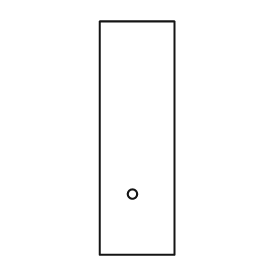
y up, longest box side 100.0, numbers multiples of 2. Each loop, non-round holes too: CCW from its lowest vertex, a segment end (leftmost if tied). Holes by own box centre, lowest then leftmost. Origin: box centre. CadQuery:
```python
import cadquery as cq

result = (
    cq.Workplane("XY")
    .moveTo(-16.0, -50.0)
    .lineTo(16.0, -50.0)
    .lineTo(16.0, 50.0)
    .lineTo(-16.0, 50.0)
    .close()
    .moveTo(-2.0, -24.0)
    .circle(2.0)
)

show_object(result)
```